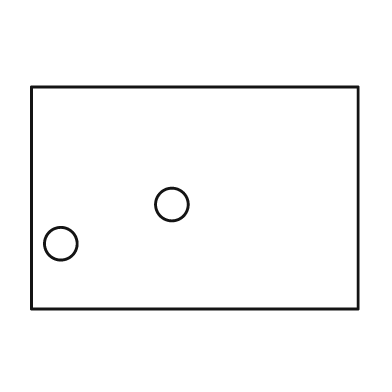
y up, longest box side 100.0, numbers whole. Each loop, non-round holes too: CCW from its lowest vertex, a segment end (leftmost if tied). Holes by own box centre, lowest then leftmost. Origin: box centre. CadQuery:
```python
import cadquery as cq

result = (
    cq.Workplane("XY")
    .moveTo(-50.0, -34.0)
    .lineTo(50.0, -34.0)
    .lineTo(50.0, 34.0)
    .lineTo(-50.0, 34.0)
    .close()
    .moveTo(-41.0, -14.0)
    .circle(5.0)
    .moveTo(-7.0, -2.0)
    .circle(5.0)
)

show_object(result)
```